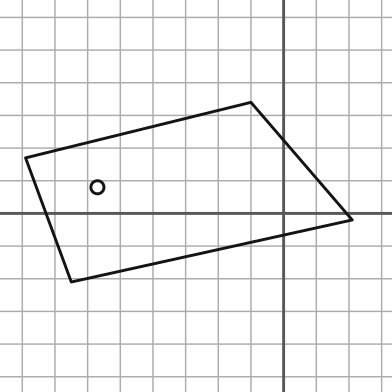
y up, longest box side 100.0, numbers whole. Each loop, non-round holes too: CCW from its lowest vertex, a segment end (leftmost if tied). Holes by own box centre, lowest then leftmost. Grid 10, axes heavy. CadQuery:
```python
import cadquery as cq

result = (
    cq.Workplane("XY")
    .moveTo(-65.0, -21.0)
    .lineTo(21.0, -2.0)
    .lineTo(-10.0, 34.0)
    .lineTo(-79.0, 17.0)
    .close()
    .moveTo(-57.0, 8.0)
    .circle(2.0)
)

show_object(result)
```